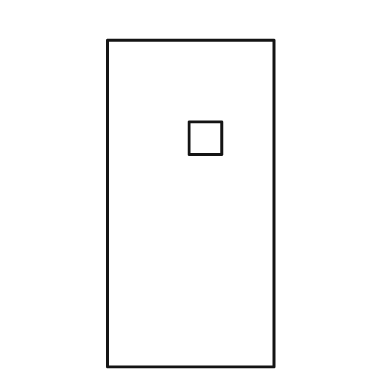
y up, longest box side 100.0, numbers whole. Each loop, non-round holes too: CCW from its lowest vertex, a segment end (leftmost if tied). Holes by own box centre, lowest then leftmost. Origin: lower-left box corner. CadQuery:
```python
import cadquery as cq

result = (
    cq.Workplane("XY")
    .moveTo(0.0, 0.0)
    .lineTo(51.0, 0.0)
    .lineTo(51.0, 100.0)
    .lineTo(0.0, 100.0)
    .close()
    .moveTo(25.0, 65.0)
    .lineTo(35.0, 65.0)
    .lineTo(35.0, 75.0)
    .lineTo(25.0, 75.0)
    .close()
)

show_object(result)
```